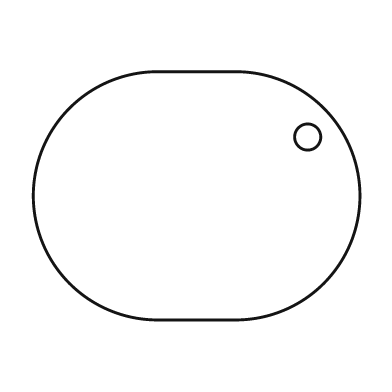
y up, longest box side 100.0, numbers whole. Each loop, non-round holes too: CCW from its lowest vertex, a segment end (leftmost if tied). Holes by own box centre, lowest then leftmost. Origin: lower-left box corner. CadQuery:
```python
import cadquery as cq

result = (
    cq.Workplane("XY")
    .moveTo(38.0, 0.0)
    .lineTo(62.0, 0.0)
    .threePointArc((100.0, 38.0), (62.0, 76.0))
    .lineTo(38.0, 76.0)
    .threePointArc((0.0, 38.0), (38.0, 0.0))
    .close()
    .moveTo(84.0, 56.0)
    .circle(4.0)
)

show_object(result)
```